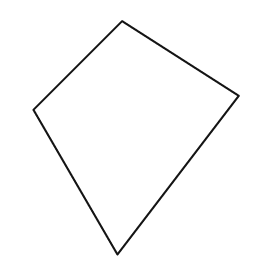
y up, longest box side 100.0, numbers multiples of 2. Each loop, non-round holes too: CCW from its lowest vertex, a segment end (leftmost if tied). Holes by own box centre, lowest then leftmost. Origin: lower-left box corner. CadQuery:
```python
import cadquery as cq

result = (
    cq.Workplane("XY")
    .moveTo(36.0, 0.0)
    .lineTo(88.0, 68.0)
    .lineTo(38.0, 100.0)
    .lineTo(0.0, 62.0)
    .close()
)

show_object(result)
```